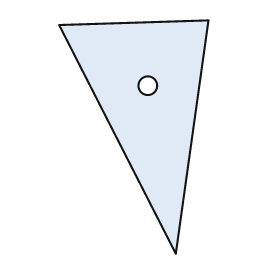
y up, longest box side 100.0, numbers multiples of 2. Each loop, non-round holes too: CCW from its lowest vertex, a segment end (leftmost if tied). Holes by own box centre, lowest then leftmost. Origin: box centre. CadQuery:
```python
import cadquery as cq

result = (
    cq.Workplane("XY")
    .moveTo(18.0, -50.0)
    .lineTo(32.0, 50.0)
    .lineTo(-32.0, 48.0)
    .close()
    .moveTo(6.0, 22.0)
    .circle(4.0)
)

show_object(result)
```